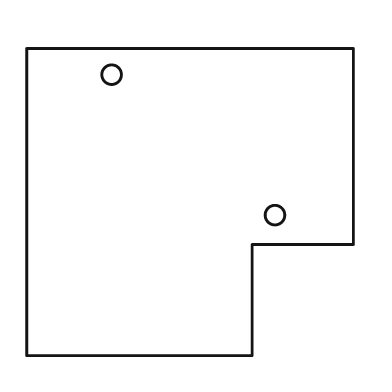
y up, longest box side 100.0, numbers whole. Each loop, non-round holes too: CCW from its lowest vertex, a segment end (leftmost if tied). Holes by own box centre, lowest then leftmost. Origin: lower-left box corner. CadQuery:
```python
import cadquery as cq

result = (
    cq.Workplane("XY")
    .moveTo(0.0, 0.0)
    .lineTo(69.0, 0.0)
    .lineTo(69.0, 34.0)
    .lineTo(100.0, 34.0)
    .lineTo(100.0, 94.0)
    .lineTo(0.0, 94.0)
    .close()
    .moveTo(76.0, 43.0)
    .circle(3.0)
    .moveTo(26.0, 86.0)
    .circle(3.0)
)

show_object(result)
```